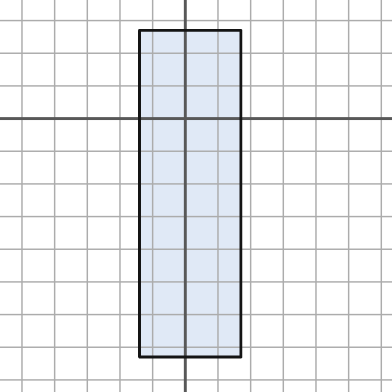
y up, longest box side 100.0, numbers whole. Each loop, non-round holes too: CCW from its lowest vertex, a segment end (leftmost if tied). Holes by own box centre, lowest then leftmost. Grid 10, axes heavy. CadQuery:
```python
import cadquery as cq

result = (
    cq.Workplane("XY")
    .moveTo(-14.0, -73.0)
    .lineTo(17.0, -73.0)
    .lineTo(17.0, 27.0)
    .lineTo(-14.0, 27.0)
    .close()
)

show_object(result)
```